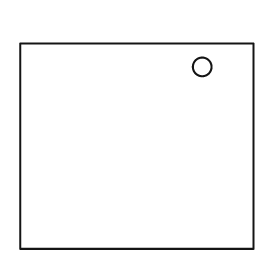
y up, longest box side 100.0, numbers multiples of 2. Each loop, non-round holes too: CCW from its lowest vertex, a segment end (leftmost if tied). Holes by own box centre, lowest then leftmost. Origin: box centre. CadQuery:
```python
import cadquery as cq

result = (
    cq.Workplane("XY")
    .moveTo(-50.0, -44.0)
    .lineTo(50.0, -44.0)
    .lineTo(50.0, 44.0)
    .lineTo(-50.0, 44.0)
    .close()
    .moveTo(28.0, 34.0)
    .circle(4.0)
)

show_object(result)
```